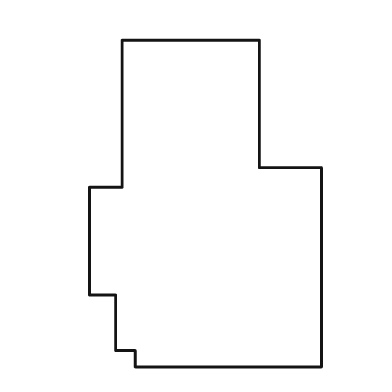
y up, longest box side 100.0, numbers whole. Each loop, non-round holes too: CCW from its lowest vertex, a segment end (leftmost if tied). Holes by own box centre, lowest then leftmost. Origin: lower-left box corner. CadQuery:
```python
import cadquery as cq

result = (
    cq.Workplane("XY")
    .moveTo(14.0, 0.0)
    .lineTo(71.0, 0.0)
    .lineTo(71.0, 61.0)
    .lineTo(52.0, 61.0)
    .lineTo(52.0, 100.0)
    .lineTo(10.0, 100.0)
    .lineTo(10.0, 55.0)
    .lineTo(0.0, 55.0)
    .lineTo(0.0, 22.0)
    .lineTo(8.0, 22.0)
    .lineTo(8.0, 5.0)
    .lineTo(14.0, 5.0)
    .close()
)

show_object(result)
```